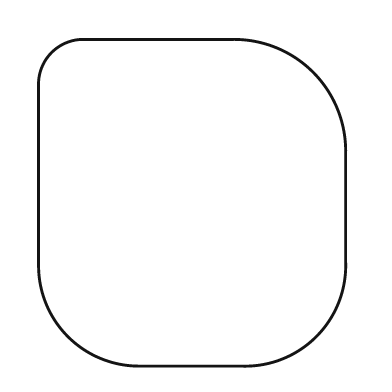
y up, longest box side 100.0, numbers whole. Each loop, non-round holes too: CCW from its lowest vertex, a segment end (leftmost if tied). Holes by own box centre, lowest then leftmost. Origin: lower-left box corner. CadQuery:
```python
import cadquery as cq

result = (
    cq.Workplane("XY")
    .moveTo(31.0, 0.0)
    .lineTo(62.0, 0.0)
    .threePointArc((85.0, 9.0), (94.0, 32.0))
    .lineTo(94.0, 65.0)
    .threePointArc((84.0, 90.0), (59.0, 100.0))
    .lineTo(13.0, 100.0)
    .threePointArc((4.0, 96.0), (0.0, 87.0))
    .lineTo(0.0, 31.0)
    .threePointArc((9.0, 9.0), (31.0, 0.0))
    .close()
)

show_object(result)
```